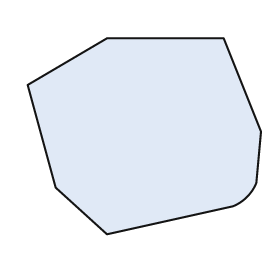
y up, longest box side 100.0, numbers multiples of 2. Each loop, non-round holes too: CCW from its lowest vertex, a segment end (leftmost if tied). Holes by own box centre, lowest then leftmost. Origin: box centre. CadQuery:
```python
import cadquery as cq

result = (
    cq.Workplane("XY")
    .moveTo(-16.0, -42.0)
    .lineTo(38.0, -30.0)
    .threePointArc((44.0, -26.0), (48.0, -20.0))
    .lineTo(50.0, 2.0)
    .lineTo(34.0, 42.0)
    .lineTo(-16.0, 42.0)
    .lineTo(-50.0, 22.0)
    .lineTo(-38.0, -22.0)
    .close()
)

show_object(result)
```